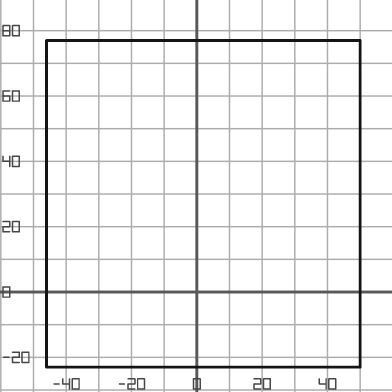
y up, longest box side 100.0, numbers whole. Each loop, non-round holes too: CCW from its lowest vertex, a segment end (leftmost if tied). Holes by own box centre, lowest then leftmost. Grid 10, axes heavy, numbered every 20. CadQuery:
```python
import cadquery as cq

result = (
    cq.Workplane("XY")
    .moveTo(-46.0, -23.0)
    .lineTo(50.0, -23.0)
    .lineTo(50.0, 77.0)
    .lineTo(-46.0, 77.0)
    .close()
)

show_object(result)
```